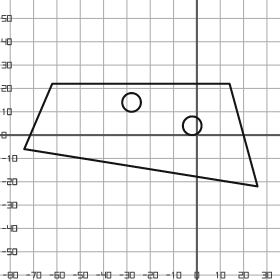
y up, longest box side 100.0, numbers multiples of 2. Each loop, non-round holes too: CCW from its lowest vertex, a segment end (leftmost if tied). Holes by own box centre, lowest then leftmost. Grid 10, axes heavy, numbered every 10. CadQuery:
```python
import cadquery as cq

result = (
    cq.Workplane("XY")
    .moveTo(26.0, -22.0)
    .lineTo(14.0, 22.0)
    .lineTo(-62.0, 22.0)
    .lineTo(-74.0, -6.0)
    .close()
    .moveTo(-2.0, 4.0)
    .circle(4.0)
    .moveTo(-28.0, 14.0)
    .circle(4.0)
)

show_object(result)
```